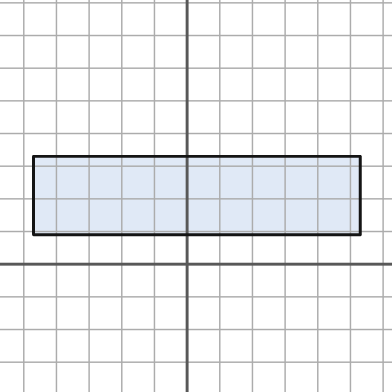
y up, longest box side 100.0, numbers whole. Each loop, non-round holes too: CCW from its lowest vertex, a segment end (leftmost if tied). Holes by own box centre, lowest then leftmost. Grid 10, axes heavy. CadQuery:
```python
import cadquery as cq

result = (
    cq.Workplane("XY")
    .moveTo(-47.0, 9.0)
    .lineTo(53.0, 9.0)
    .lineTo(53.0, 33.0)
    .lineTo(-47.0, 33.0)
    .close()
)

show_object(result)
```